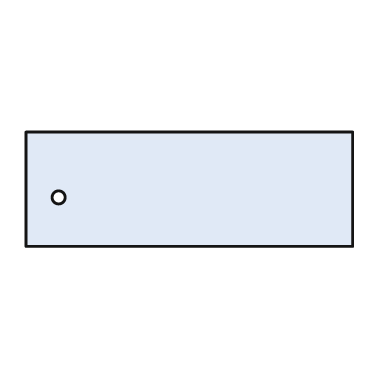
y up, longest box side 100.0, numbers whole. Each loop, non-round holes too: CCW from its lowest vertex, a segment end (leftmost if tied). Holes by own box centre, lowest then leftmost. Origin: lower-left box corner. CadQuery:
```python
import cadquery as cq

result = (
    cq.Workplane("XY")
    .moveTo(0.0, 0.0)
    .lineTo(100.0, 0.0)
    .lineTo(100.0, 35.0)
    .lineTo(0.0, 35.0)
    .close()
    .moveTo(10.0, 15.0)
    .circle(2.0)
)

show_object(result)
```